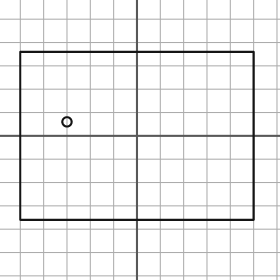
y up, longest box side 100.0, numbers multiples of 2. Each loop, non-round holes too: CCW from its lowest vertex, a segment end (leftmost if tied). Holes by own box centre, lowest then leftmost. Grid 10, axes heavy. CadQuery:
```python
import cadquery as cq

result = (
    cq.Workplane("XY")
    .moveTo(-50.0, -36.0)
    .lineTo(50.0, -36.0)
    .lineTo(50.0, 36.0)
    .lineTo(-50.0, 36.0)
    .close()
    .moveTo(-30.0, 6.0)
    .circle(2.0)
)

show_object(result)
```